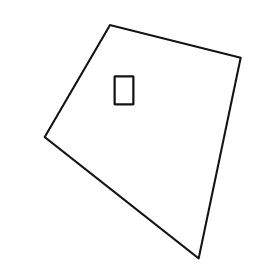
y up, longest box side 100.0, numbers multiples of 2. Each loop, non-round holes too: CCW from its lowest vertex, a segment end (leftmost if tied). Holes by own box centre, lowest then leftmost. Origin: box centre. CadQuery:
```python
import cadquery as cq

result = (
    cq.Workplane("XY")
    .moveTo(24.0, -50.0)
    .lineTo(42.0, 36.0)
    .lineTo(-14.0, 50.0)
    .lineTo(-42.0, 2.0)
    .close()
    .moveTo(-12.0, 16.0)
    .lineTo(-4.0, 16.0)
    .lineTo(-4.0, 28.0)
    .lineTo(-12.0, 28.0)
    .close()
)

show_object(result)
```